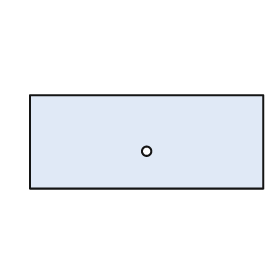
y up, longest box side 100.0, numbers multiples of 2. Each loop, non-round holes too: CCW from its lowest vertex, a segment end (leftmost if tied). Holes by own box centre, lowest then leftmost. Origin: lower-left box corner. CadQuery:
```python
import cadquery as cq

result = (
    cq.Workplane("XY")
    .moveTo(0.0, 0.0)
    .lineTo(100.0, 0.0)
    .lineTo(100.0, 40.0)
    .lineTo(0.0, 40.0)
    .close()
    .moveTo(50.0, 16.0)
    .circle(2.0)
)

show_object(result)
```